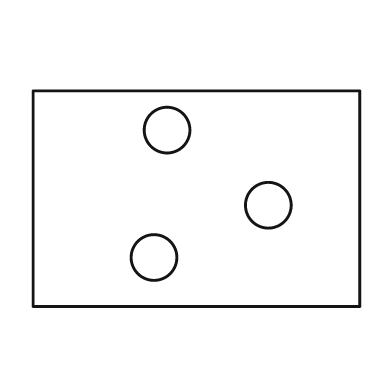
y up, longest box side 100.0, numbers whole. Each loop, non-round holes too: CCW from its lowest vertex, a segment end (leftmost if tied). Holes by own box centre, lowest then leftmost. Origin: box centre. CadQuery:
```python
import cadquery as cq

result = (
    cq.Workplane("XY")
    .moveTo(-50.0, -33.0)
    .lineTo(50.0, -33.0)
    .lineTo(50.0, 33.0)
    .lineTo(-50.0, 33.0)
    .close()
    .moveTo(-13.0, -18.0)
    .circle(7.0)
    .moveTo(22.0, -2.0)
    .circle(7.0)
    .moveTo(-9.0, 21.0)
    .circle(7.0)
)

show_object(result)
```